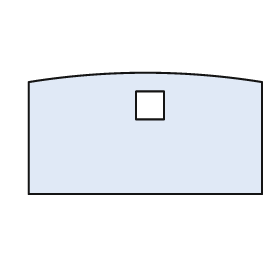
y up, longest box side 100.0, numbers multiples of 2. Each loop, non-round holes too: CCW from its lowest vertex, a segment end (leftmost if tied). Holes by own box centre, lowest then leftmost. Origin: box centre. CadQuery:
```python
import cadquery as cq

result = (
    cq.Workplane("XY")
    .moveTo(-50.0, -26.0)
    .lineTo(50.0, -26.0)
    .lineTo(50.0, 22.0)
    .threePointArc((0.0, 26.0), (-50.0, 22.0))
    .close()
    .moveTo(-4.0, 6.0)
    .lineTo(8.0, 6.0)
    .lineTo(8.0, 18.0)
    .lineTo(-4.0, 18.0)
    .close()
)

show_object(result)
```